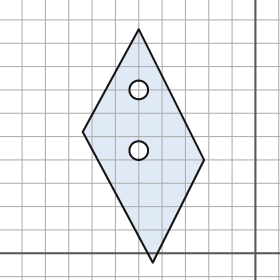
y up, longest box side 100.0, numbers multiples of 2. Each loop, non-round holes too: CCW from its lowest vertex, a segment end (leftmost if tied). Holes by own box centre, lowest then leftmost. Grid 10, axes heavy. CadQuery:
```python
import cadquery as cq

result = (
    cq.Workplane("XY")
    .moveTo(-44.0, -4.0)
    .lineTo(-22.0, 40.0)
    .lineTo(-50.0, 96.0)
    .lineTo(-74.0, 52.0)
    .close()
    .moveTo(-50.0, 44.0)
    .circle(4.0)
    .moveTo(-50.0, 70.0)
    .circle(4.0)
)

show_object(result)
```